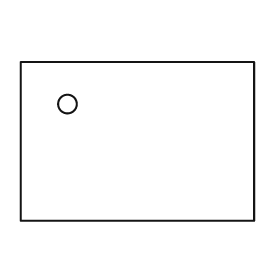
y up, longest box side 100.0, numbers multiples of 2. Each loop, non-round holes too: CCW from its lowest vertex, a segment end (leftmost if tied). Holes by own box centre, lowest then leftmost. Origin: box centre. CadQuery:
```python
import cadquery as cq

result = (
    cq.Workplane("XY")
    .moveTo(-50.0, -34.0)
    .lineTo(50.0, -34.0)
    .lineTo(50.0, 34.0)
    .lineTo(-50.0, 34.0)
    .close()
    .moveTo(-30.0, 16.0)
    .circle(4.0)
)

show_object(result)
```